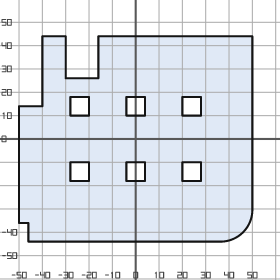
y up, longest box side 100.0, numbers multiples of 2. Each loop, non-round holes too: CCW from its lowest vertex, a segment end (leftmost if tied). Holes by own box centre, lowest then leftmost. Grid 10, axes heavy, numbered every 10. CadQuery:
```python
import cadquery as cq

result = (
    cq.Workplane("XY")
    .moveTo(-46.0, -44.0)
    .lineTo(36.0, -44.0)
    .threePointArc((46.0, -40.0), (50.0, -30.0))
    .lineTo(50.0, 44.0)
    .lineTo(-16.0, 44.0)
    .lineTo(-16.0, 26.0)
    .lineTo(-30.0, 26.0)
    .lineTo(-30.0, 44.0)
    .lineTo(-40.0, 44.0)
    .lineTo(-40.0, 14.0)
    .lineTo(-50.0, 14.0)
    .lineTo(-50.0, -36.0)
    .lineTo(-46.0, -36.0)
    .close()
    .moveTo(-28.0, -18.0)
    .lineTo(-20.0, -18.0)
    .lineTo(-20.0, -10.0)
    .lineTo(-28.0, -10.0)
    .close()
    .moveTo(-4.0, -18.0)
    .lineTo(4.0, -18.0)
    .lineTo(4.0, -10.0)
    .lineTo(-4.0, -10.0)
    .close()
    .moveTo(20.0, -18.0)
    .lineTo(28.0, -18.0)
    .lineTo(28.0, -10.0)
    .lineTo(20.0, -10.0)
    .close()
    .moveTo(-28.0, 10.0)
    .lineTo(-20.0, 10.0)
    .lineTo(-20.0, 18.0)
    .lineTo(-28.0, 18.0)
    .close()
    .moveTo(-4.0, 10.0)
    .lineTo(4.0, 10.0)
    .lineTo(4.0, 18.0)
    .lineTo(-4.0, 18.0)
    .close()
    .moveTo(20.0, 10.0)
    .lineTo(28.0, 10.0)
    .lineTo(28.0, 18.0)
    .lineTo(20.0, 18.0)
    .close()
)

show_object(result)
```